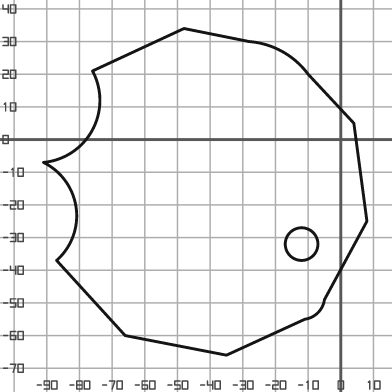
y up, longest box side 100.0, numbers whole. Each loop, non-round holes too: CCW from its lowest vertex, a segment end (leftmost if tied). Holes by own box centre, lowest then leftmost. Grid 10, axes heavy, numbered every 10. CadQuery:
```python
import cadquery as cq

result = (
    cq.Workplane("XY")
    .moveTo(-35.0, -66.0)
    .lineTo(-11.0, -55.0)
    .threePointArc((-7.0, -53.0), (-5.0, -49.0))
    .lineTo(8.0, -25.0)
    .lineTo(4.0, 5.0)
    .lineTo(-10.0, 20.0)
    .threePointArc((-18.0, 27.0), (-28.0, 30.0))
    .lineTo(-48.0, 34.0)
    .lineTo(-76.0, 21.0)
    .threePointArc((-76.0, 3.0), (-91.0, -7.0))
    .threePointArc((-81.0, -21.0), (-87.0, -37.0))
    .lineTo(-66.0, -60.0)
    .close()
    .moveTo(-12.0, -32.0)
    .circle(5.0)
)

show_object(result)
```